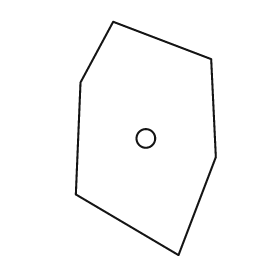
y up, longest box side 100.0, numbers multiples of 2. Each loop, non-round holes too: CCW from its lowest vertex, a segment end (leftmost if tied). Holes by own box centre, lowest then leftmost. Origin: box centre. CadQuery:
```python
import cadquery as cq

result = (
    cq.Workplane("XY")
    .moveTo(14.0, -50.0)
    .lineTo(30.0, -8.0)
    .lineTo(28.0, 34.0)
    .lineTo(-14.0, 50.0)
    .lineTo(-28.0, 24.0)
    .lineTo(-30.0, -24.0)
    .close()
    .moveTo(0.0, 0.0)
    .circle(4.0)
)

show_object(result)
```